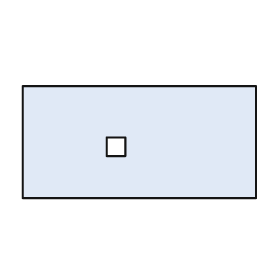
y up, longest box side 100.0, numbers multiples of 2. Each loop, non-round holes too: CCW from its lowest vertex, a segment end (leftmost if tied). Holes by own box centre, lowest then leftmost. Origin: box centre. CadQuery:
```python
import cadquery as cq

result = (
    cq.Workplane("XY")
    .moveTo(-50.0, -24.0)
    .lineTo(50.0, -24.0)
    .lineTo(50.0, 24.0)
    .lineTo(-50.0, 24.0)
    .close()
    .moveTo(-14.0, -6.0)
    .lineTo(-6.0, -6.0)
    .lineTo(-6.0, 2.0)
    .lineTo(-14.0, 2.0)
    .close()
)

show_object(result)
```